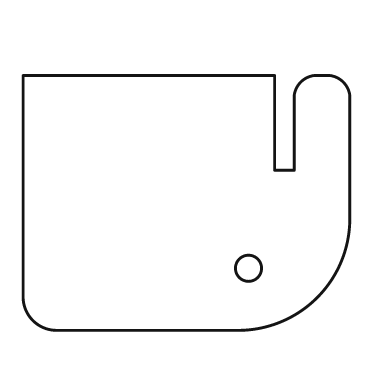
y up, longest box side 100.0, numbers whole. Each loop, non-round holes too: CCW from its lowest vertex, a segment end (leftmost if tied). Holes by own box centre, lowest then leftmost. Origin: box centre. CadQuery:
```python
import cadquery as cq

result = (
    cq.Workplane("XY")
    .moveTo(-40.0, -39.0)
    .lineTo(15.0, -39.0)
    .threePointArc((40.0, -29.0), (50.0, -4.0))
    .lineTo(50.0, 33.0)
    .threePointArc((48.0, 37.0), (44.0, 39.0))
    .lineTo(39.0, 39.0)
    .threePointArc((35.0, 37.0), (33.0, 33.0))
    .lineTo(33.0, 10.0)
    .lineTo(27.0, 10.0)
    .lineTo(27.0, 39.0)
    .lineTo(-50.0, 39.0)
    .lineTo(-50.0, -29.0)
    .threePointArc((-47.0, -36.0), (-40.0, -39.0))
    .close()
    .moveTo(19.0, -20.0)
    .circle(4.0)
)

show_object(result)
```